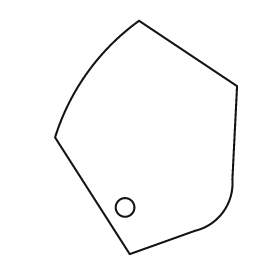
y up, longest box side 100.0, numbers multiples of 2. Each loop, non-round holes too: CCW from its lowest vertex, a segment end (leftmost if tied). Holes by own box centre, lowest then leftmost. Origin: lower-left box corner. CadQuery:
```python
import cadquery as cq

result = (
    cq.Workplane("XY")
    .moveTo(32.0, 0.0)
    .lineTo(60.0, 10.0)
    .threePointArc((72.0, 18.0), (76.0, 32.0))
    .lineTo(78.0, 72.0)
    .lineTo(36.0, 100.0)
    .threePointArc((14.0, 78.0), (0.0, 50.0))
    .close()
    .moveTo(30.0, 20.0)
    .circle(4.0)
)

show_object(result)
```